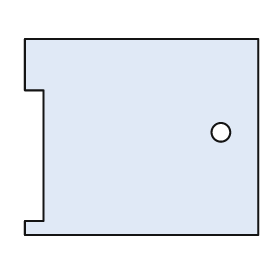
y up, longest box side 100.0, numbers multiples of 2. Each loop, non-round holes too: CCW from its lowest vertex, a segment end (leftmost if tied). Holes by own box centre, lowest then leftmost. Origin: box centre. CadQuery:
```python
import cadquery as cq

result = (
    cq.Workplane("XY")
    .moveTo(-50.0, -42.0)
    .lineTo(50.0, -42.0)
    .lineTo(50.0, 42.0)
    .lineTo(-50.0, 42.0)
    .lineTo(-50.0, 20.0)
    .lineTo(-42.0, 20.0)
    .lineTo(-42.0, -36.0)
    .lineTo(-50.0, -36.0)
    .close()
    .moveTo(34.0, 2.0)
    .circle(4.0)
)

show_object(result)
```